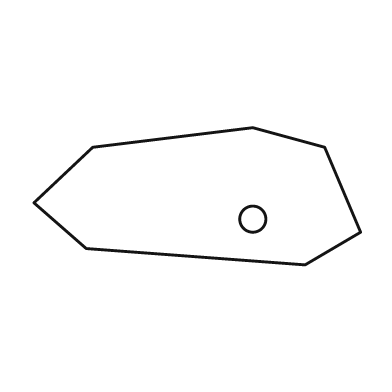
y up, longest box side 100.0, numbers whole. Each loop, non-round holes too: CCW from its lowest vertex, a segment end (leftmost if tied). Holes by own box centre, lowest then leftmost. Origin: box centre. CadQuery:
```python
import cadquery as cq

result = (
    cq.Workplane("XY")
    .moveTo(33.0, -21.0)
    .lineTo(50.0, -11.0)
    .lineTo(39.0, 15.0)
    .lineTo(17.0, 21.0)
    .lineTo(-32.0, 15.0)
    .lineTo(-50.0, -2.0)
    .lineTo(-34.0, -16.0)
    .close()
    .moveTo(17.0, -7.0)
    .circle(4.0)
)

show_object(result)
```